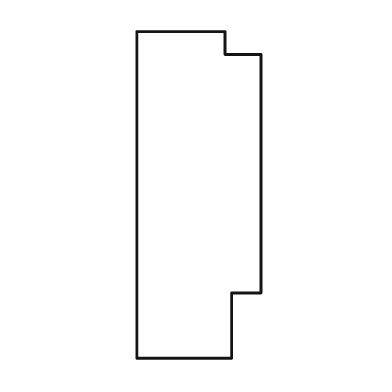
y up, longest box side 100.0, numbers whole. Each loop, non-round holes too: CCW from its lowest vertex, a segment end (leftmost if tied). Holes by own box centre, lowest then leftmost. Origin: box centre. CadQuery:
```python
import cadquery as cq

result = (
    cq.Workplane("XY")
    .moveTo(-19.0, -50.0)
    .lineTo(10.0, -50.0)
    .lineTo(10.0, -30.0)
    .lineTo(19.0, -30.0)
    .lineTo(19.0, 43.0)
    .lineTo(8.0, 43.0)
    .lineTo(8.0, 50.0)
    .lineTo(-19.0, 50.0)
    .close()
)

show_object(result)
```